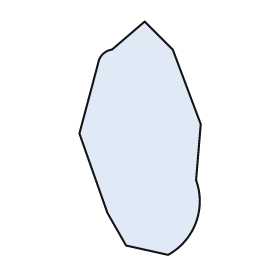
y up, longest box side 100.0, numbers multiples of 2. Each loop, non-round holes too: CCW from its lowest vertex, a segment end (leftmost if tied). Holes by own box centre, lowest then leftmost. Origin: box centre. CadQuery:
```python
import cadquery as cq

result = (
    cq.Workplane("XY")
    .moveTo(12.0, -50.0)
    .threePointArc((24.0, -36.0), (24.0, -18.0))
    .lineTo(26.0, 6.0)
    .lineTo(14.0, 38.0)
    .lineTo(2.0, 50.0)
    .lineTo(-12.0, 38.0)
    .threePointArc((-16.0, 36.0), (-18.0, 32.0))
    .lineTo(-26.0, 2.0)
    .lineTo(-14.0, -32.0)
    .lineTo(-6.0, -46.0)
    .close()
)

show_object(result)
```